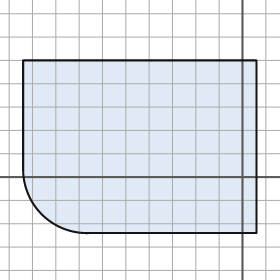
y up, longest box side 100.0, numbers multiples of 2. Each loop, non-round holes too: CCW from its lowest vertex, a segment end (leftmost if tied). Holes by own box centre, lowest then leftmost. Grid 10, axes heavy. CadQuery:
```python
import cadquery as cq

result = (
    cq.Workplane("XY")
    .moveTo(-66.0, -24.0)
    .lineTo(6.0, -24.0)
    .lineTo(6.0, 50.0)
    .lineTo(-94.0, 50.0)
    .lineTo(-94.0, 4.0)
    .threePointArc((-86.0, -16.0), (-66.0, -24.0))
    .close()
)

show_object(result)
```